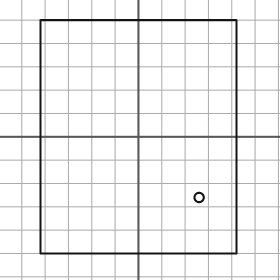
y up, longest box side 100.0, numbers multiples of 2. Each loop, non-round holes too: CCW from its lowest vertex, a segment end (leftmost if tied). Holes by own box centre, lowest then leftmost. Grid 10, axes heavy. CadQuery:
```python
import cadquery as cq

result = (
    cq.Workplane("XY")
    .moveTo(-42.0, -50.0)
    .lineTo(42.0, -50.0)
    .lineTo(42.0, 50.0)
    .lineTo(-42.0, 50.0)
    .close()
    .moveTo(26.0, -26.0)
    .circle(2.0)
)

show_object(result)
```